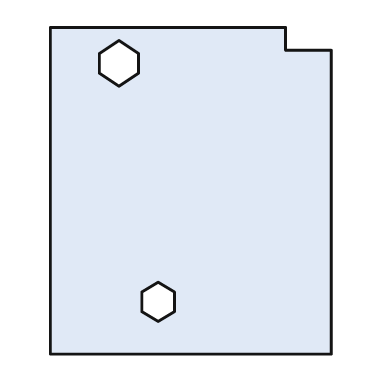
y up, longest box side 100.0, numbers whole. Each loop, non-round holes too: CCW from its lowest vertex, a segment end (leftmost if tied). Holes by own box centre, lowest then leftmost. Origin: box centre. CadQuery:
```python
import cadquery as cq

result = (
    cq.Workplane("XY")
    .moveTo(-43.0, -50.0)
    .lineTo(43.0, -50.0)
    .lineTo(43.0, 43.0)
    .lineTo(29.0, 43.0)
    .lineTo(29.0, 50.0)
    .lineTo(-43.0, 50.0)
    .close()
    .moveTo(-10.0, -40.0)
    .lineTo(-5.0, -37.0)
    .lineTo(-5.0, -31.0)
    .lineTo(-10.0, -28.0)
    .lineTo(-15.0, -31.0)
    .lineTo(-15.0, -37.0)
    .close()
    .moveTo(-22.0, 32.0)
    .lineTo(-16.0, 36.0)
    .lineTo(-16.0, 42.0)
    .lineTo(-22.0, 46.0)
    .lineTo(-28.0, 42.0)
    .lineTo(-28.0, 36.0)
    .close()
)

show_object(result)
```